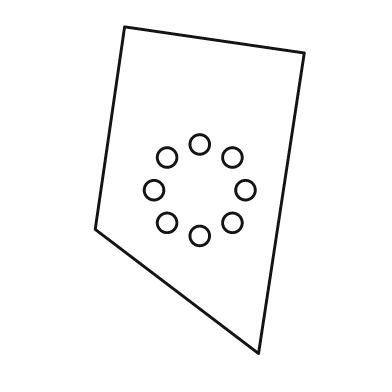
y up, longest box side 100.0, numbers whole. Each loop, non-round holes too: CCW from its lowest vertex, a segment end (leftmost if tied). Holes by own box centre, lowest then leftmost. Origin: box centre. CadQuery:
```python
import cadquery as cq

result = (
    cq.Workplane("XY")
    .moveTo(18.0, -50.0)
    .lineTo(32.0, 42.0)
    .lineTo(-23.0, 50.0)
    .lineTo(-32.0, -12.0)
    .close()
    .moveTo(0.0, -14.0)
    .circle(3.0)
    .moveTo(-10.0, -10.0)
    .circle(3.0)
    .moveTo(10.0, -10.0)
    .circle(3.0)
    .moveTo(-14.0, 0.0)
    .circle(3.0)
    .moveTo(14.0, 0.0)
    .circle(3.0)
    .moveTo(-10.0, 10.0)
    .circle(3.0)
    .moveTo(10.0, 10.0)
    .circle(3.0)
    .moveTo(0.0, 14.0)
    .circle(3.0)
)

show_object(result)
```